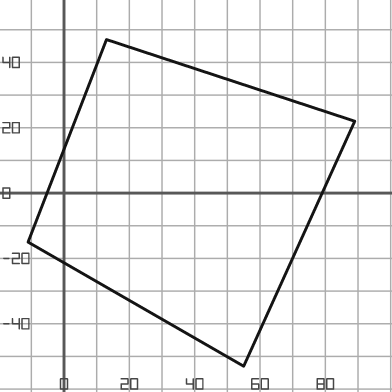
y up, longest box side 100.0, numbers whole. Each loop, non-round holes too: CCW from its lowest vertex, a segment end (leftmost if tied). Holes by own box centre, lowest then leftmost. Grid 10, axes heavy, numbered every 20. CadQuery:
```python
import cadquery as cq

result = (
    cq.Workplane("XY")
    .moveTo(55.0, -53.0)
    .lineTo(89.0, 22.0)
    .lineTo(13.0, 47.0)
    .lineTo(-11.0, -15.0)
    .close()
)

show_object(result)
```